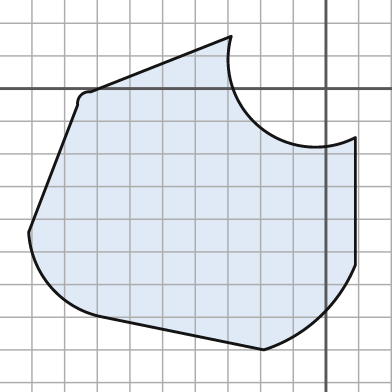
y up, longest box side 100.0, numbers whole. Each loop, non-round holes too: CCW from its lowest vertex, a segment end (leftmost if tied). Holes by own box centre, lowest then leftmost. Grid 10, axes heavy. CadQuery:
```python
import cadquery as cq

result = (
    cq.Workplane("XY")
    .moveTo(-19.0, -80.0)
    .threePointArc((-2.0, -70.0), (9.0, -54.0))
    .lineTo(9.0, -15.0)
    .threePointArc((-20.0, -12.0), (-29.0, 16.0))
    .lineTo(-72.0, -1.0)
    .threePointArc((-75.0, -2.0), (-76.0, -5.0))
    .lineTo(-91.0, -44.0)
    .threePointArc((-84.0, -61.0), (-68.0, -70.0))
    .close()
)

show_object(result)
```